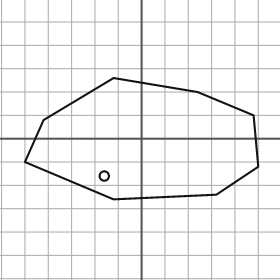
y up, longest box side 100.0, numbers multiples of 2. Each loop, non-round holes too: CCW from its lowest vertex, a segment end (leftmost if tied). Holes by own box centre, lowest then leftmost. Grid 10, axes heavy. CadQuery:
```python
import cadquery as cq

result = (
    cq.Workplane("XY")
    .moveTo(-12.0, -26.0)
    .lineTo(32.0, -24.0)
    .lineTo(50.0, -12.0)
    .lineTo(48.0, 10.0)
    .lineTo(24.0, 20.0)
    .lineTo(-12.0, 26.0)
    .lineTo(-42.0, 8.0)
    .lineTo(-50.0, -10.0)
    .close()
    .moveTo(-16.0, -16.0)
    .circle(2.0)
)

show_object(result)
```